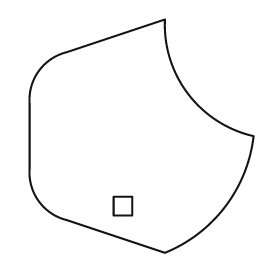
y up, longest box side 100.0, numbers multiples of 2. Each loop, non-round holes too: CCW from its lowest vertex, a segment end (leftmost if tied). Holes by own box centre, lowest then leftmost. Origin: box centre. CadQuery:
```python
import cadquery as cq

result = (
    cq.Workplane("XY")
    .moveTo(10.0, -50.0)
    .threePointArc((36.0, -30.0), (48.0, 0.0))
    .threePointArc((20.0, 18.0), (10.0, 50.0))
    .lineTo(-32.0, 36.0)
    .threePointArc((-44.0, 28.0), (-48.0, 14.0))
    .lineTo(-48.0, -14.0)
    .threePointArc((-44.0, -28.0), (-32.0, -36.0))
    .close()
    .moveTo(-12.0, -34.0)
    .lineTo(-4.0, -34.0)
    .lineTo(-4.0, -26.0)
    .lineTo(-12.0, -26.0)
    .close()
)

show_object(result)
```